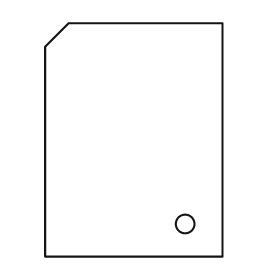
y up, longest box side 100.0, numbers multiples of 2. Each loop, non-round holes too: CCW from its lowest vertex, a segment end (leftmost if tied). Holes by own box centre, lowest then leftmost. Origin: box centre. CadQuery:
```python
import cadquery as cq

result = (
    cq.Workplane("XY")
    .moveTo(-38.0, -50.0)
    .lineTo(38.0, -50.0)
    .lineTo(38.0, 50.0)
    .lineTo(-28.0, 50.0)
    .lineTo(-38.0, 40.0)
    .close()
    .moveTo(22.0, -36.0)
    .circle(4.0)
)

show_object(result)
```